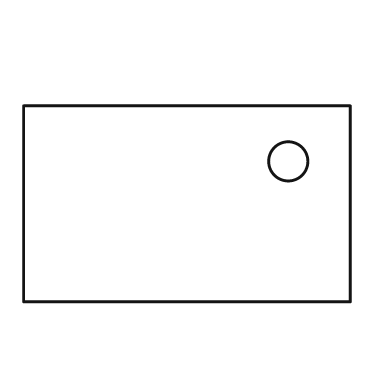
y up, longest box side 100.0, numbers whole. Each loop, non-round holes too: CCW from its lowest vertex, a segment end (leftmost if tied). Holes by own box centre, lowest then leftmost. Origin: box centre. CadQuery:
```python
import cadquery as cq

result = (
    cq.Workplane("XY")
    .moveTo(-50.0, -30.0)
    .lineTo(50.0, -30.0)
    .lineTo(50.0, 30.0)
    .lineTo(-50.0, 30.0)
    .close()
    .moveTo(31.0, 13.0)
    .circle(6.0)
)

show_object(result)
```